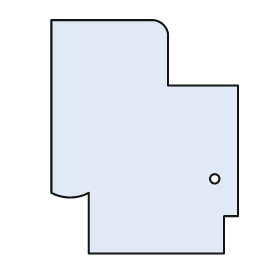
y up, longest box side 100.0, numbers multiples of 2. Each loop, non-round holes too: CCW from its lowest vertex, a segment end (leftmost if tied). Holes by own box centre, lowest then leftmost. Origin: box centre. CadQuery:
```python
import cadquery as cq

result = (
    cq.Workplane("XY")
    .moveTo(-24.0, -50.0)
    .lineTo(34.0, -50.0)
    .lineTo(34.0, -34.0)
    .lineTo(40.0, -34.0)
    .lineTo(40.0, 22.0)
    .lineTo(10.0, 22.0)
    .lineTo(10.0, 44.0)
    .threePointArc((8.0, 48.0), (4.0, 50.0))
    .lineTo(-40.0, 50.0)
    .lineTo(-40.0, -24.0)
    .threePointArc((-32.0, -26.0), (-24.0, -24.0))
    .close()
    .moveTo(30.0, -18.0)
    .circle(2.0)
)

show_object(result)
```